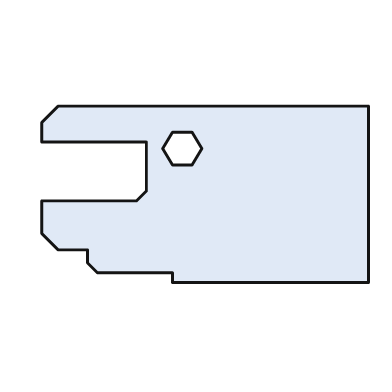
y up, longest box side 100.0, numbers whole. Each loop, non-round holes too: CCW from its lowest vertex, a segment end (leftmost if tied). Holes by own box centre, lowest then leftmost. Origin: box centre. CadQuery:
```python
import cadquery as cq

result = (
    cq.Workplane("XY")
    .moveTo(-10.0, -27.0)
    .lineTo(50.0, -27.0)
    .lineTo(50.0, 27.0)
    .lineTo(-45.0, 27.0)
    .lineTo(-50.0, 22.0)
    .lineTo(-50.0, 16.0)
    .lineTo(-18.0, 16.0)
    .lineTo(-18.0, 1.0)
    .lineTo(-21.0, -2.0)
    .lineTo(-50.0, -2.0)
    .lineTo(-50.0, -12.0)
    .lineTo(-45.0, -17.0)
    .lineTo(-36.0, -17.0)
    .lineTo(-36.0, -21.0)
    .lineTo(-33.0, -24.0)
    .lineTo(-10.0, -24.0)
    .close()
    .moveTo(-10.0, 9.0)
    .lineTo(-4.0, 9.0)
    .lineTo(-1.0, 14.0)
    .lineTo(-4.0, 19.0)
    .lineTo(-10.0, 19.0)
    .lineTo(-13.0, 14.0)
    .close()
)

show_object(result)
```